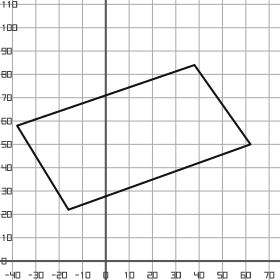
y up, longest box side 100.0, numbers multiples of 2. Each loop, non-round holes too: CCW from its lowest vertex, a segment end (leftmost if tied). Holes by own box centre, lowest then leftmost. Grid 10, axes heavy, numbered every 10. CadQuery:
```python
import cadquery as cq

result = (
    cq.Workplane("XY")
    .moveTo(-16.0, 22.0)
    .lineTo(62.0, 50.0)
    .lineTo(38.0, 84.0)
    .lineTo(-38.0, 58.0)
    .close()
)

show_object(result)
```